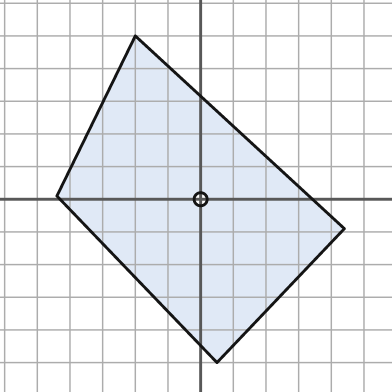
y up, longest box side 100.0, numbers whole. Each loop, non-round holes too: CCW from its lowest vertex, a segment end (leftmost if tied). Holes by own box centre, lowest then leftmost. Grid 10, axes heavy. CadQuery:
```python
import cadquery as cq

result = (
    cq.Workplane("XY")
    .moveTo(5.0, -50.0)
    .lineTo(44.0, -9.0)
    .lineTo(-20.0, 50.0)
    .lineTo(-44.0, 1.0)
    .close()
    .moveTo(0.0, 0.0)
    .circle(2.0)
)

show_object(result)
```